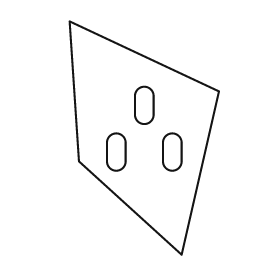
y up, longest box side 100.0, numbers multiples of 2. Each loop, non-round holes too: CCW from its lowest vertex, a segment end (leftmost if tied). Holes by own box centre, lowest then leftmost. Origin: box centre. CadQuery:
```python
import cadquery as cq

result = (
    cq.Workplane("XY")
    .moveTo(16.0, -50.0)
    .lineTo(32.0, 20.0)
    .lineTo(-32.0, 50.0)
    .lineTo(-28.0, -10.0)
    .close()
    .moveTo(-16.0, -10.0)
    .threePointArc((-12.0, -14.0), (-8.0, -10.0))
    .lineTo(-8.0, -2.0)
    .threePointArc((-12.0, 2.0), (-16.0, -2.0))
    .close()
    .moveTo(8.0, -10.0)
    .threePointArc((12.0, -14.0), (16.0, -10.0))
    .lineTo(16.0, -2.0)
    .threePointArc((12.0, 2.0), (8.0, -2.0))
    .close()
    .moveTo(-4.0, 10.0)
    .threePointArc((0.0, 6.0), (4.0, 10.0))
    .lineTo(4.0, 18.0)
    .threePointArc((0.0, 22.0), (-4.0, 18.0))
    .close()
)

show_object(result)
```